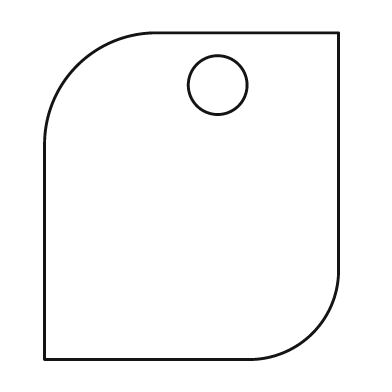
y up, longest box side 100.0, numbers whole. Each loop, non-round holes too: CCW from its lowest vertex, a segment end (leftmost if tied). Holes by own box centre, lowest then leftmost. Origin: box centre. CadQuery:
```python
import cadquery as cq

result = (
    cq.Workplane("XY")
    .moveTo(-45.0, -50.0)
    .lineTo(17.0, -50.0)
    .threePointArc((37.0, -42.0), (45.0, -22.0))
    .lineTo(45.0, 50.0)
    .lineTo(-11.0, 50.0)
    .threePointArc((-35.0, 40.0), (-45.0, 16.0))
    .close()
    .moveTo(8.0, 34.0)
    .circle(9.0)
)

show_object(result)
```